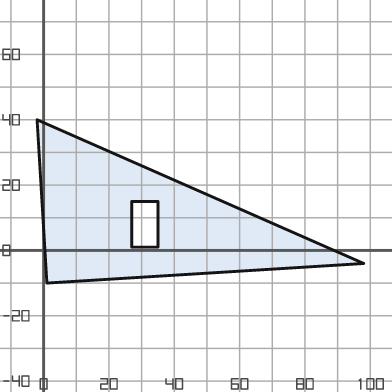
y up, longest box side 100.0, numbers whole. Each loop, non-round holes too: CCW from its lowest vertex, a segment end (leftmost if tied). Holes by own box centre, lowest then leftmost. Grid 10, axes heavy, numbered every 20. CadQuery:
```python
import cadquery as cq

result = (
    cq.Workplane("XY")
    .moveTo(1.0, -10.0)
    .lineTo(98.0, -4.0)
    .lineTo(-2.0, 40.0)
    .close()
    .moveTo(27.0, 1.0)
    .lineTo(35.0, 1.0)
    .lineTo(35.0, 15.0)
    .lineTo(27.0, 15.0)
    .close()
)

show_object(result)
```